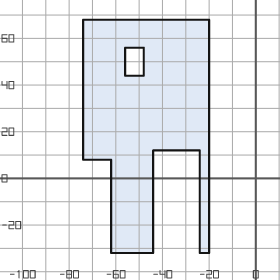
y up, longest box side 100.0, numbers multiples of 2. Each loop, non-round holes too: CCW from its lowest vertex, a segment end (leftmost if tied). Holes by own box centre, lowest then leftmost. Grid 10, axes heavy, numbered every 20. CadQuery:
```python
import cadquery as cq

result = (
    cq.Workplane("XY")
    .moveTo(-62.0, -32.0)
    .lineTo(-44.0, -32.0)
    .lineTo(-44.0, 12.0)
    .lineTo(-24.0, 12.0)
    .lineTo(-24.0, -32.0)
    .lineTo(-20.0, -32.0)
    .lineTo(-20.0, 68.0)
    .lineTo(-74.0, 68.0)
    .lineTo(-74.0, 8.0)
    .lineTo(-62.0, 8.0)
    .close()
    .moveTo(-56.0, 44.0)
    .lineTo(-48.0, 44.0)
    .lineTo(-48.0, 56.0)
    .lineTo(-56.0, 56.0)
    .close()
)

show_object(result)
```